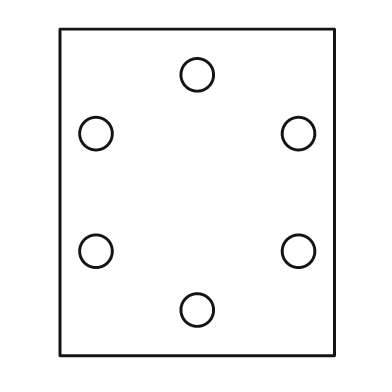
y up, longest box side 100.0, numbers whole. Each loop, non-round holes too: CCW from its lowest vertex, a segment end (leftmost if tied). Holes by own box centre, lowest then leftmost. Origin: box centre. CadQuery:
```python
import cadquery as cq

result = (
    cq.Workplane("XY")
    .moveTo(-42.0, -50.0)
    .lineTo(42.0, -50.0)
    .lineTo(42.0, 50.0)
    .lineTo(-42.0, 50.0)
    .close()
    .moveTo(0.0, -36.0)
    .circle(5.0)
    .moveTo(-31.0, -18.0)
    .circle(5.0)
    .moveTo(31.0, -18.0)
    .circle(5.0)
    .moveTo(-31.0, 18.0)
    .circle(5.0)
    .moveTo(31.0, 18.0)
    .circle(5.0)
    .moveTo(0.0, 36.0)
    .circle(5.0)
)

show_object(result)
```